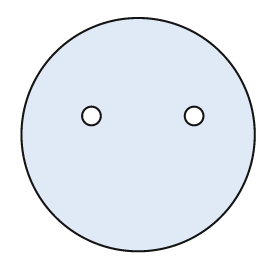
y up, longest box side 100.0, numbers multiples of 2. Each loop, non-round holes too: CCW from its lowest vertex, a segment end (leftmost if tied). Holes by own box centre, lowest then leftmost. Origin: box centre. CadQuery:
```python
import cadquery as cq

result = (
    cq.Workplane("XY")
    .moveTo(0.0, 0.0)
    .circle(50.0)
    .moveTo(-20.0, 8.0)
    .circle(4.0)
    .moveTo(24.0, 8.0)
    .circle(4.0)
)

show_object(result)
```